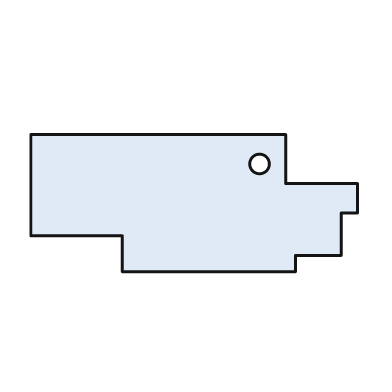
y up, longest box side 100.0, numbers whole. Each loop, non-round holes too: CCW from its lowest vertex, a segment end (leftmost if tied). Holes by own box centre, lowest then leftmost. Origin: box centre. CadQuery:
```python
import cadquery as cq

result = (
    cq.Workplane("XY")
    .moveTo(-22.0, -21.0)
    .lineTo(31.0, -21.0)
    .lineTo(31.0, -16.0)
    .lineTo(45.0, -16.0)
    .lineTo(45.0, -3.0)
    .lineTo(50.0, -3.0)
    .lineTo(50.0, 6.0)
    .lineTo(28.0, 6.0)
    .lineTo(28.0, 21.0)
    .lineTo(-50.0, 21.0)
    .lineTo(-50.0, -10.0)
    .lineTo(-22.0, -10.0)
    .close()
    .moveTo(20.0, 12.0)
    .circle(3.0)
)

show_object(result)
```